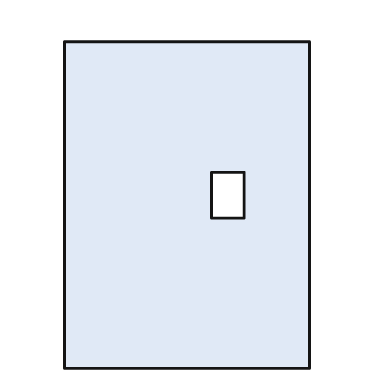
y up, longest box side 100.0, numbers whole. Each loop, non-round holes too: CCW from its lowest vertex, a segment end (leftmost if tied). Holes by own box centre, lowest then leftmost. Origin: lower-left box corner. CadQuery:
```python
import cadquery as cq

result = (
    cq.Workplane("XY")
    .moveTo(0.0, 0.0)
    .lineTo(75.0, 0.0)
    .lineTo(75.0, 100.0)
    .lineTo(0.0, 100.0)
    .close()
    .moveTo(45.0, 46.0)
    .lineTo(55.0, 46.0)
    .lineTo(55.0, 60.0)
    .lineTo(45.0, 60.0)
    .close()
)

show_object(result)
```